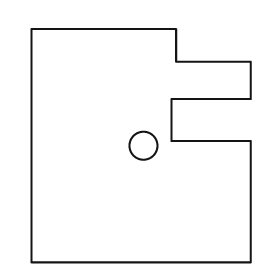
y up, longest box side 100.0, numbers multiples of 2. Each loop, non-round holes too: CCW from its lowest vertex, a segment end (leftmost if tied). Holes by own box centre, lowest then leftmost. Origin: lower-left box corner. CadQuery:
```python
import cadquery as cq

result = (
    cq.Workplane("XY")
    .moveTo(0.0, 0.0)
    .lineTo(94.0, 0.0)
    .lineTo(94.0, 52.0)
    .lineTo(60.0, 52.0)
    .lineTo(60.0, 70.0)
    .lineTo(94.0, 70.0)
    .lineTo(94.0, 86.0)
    .lineTo(62.0, 86.0)
    .lineTo(62.0, 100.0)
    .lineTo(0.0, 100.0)
    .close()
    .moveTo(48.0, 50.0)
    .circle(6.0)
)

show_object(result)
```